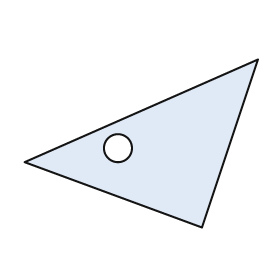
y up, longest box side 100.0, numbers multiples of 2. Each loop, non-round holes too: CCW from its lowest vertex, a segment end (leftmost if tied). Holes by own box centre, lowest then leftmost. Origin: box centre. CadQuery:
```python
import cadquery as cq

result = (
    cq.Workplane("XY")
    .moveTo(26.0, -36.0)
    .lineTo(50.0, 36.0)
    .lineTo(-50.0, -8.0)
    .close()
    .moveTo(-10.0, -2.0)
    .circle(6.0)
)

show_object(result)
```